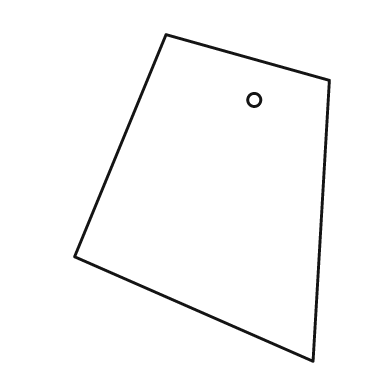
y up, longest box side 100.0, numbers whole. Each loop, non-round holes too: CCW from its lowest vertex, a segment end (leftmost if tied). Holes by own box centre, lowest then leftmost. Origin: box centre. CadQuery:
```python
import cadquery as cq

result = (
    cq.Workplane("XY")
    .moveTo(34.0, -50.0)
    .lineTo(39.0, 36.0)
    .lineTo(-11.0, 50.0)
    .lineTo(-39.0, -18.0)
    .close()
    .moveTo(16.0, 30.0)
    .circle(2.0)
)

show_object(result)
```